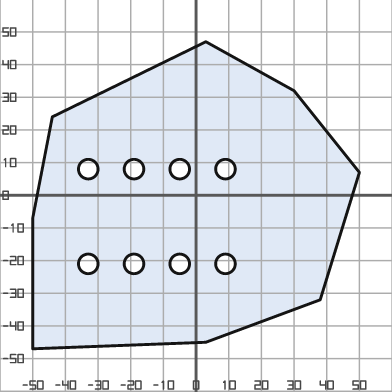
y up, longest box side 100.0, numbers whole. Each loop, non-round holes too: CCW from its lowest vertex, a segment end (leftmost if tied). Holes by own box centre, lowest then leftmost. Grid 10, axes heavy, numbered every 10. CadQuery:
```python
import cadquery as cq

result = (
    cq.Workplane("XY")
    .moveTo(-50.0, -47.0)
    .lineTo(3.0, -45.0)
    .lineTo(38.0, -32.0)
    .lineTo(50.0, 7.0)
    .lineTo(30.0, 32.0)
    .lineTo(3.0, 47.0)
    .lineTo(-44.0, 24.0)
    .lineTo(-50.0, -7.0)
    .close()
    .moveTo(-33.0, -21.0)
    .circle(3.0)
    .moveTo(-19.0, -21.0)
    .circle(3.0)
    .moveTo(-5.0, -21.0)
    .circle(3.0)
    .moveTo(9.0, -21.0)
    .circle(3.0)
    .moveTo(-33.0, 8.0)
    .circle(3.0)
    .moveTo(-19.0, 8.0)
    .circle(3.0)
    .moveTo(-5.0, 8.0)
    .circle(3.0)
    .moveTo(9.0, 8.0)
    .circle(3.0)
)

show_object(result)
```